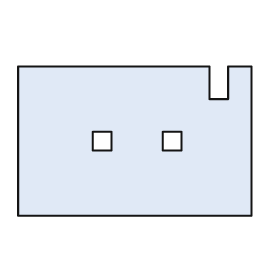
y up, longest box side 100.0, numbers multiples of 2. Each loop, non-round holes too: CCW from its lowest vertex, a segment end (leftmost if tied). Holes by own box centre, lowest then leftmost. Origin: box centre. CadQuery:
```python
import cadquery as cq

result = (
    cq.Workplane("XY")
    .moveTo(-50.0, -32.0)
    .lineTo(50.0, -32.0)
    .lineTo(50.0, 32.0)
    .lineTo(40.0, 32.0)
    .lineTo(40.0, 18.0)
    .lineTo(32.0, 18.0)
    .lineTo(32.0, 32.0)
    .lineTo(-50.0, 32.0)
    .close()
    .moveTo(-18.0, -4.0)
    .lineTo(-10.0, -4.0)
    .lineTo(-10.0, 4.0)
    .lineTo(-18.0, 4.0)
    .close()
    .moveTo(12.0, -4.0)
    .lineTo(20.0, -4.0)
    .lineTo(20.0, 4.0)
    .lineTo(12.0, 4.0)
    .close()
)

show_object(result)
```